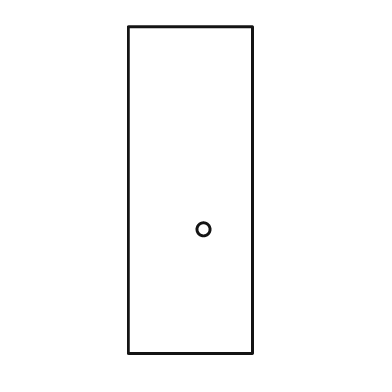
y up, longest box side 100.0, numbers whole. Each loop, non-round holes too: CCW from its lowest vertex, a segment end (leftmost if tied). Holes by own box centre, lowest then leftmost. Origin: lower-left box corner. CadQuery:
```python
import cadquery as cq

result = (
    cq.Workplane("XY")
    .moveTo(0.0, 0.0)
    .lineTo(38.0, 0.0)
    .lineTo(38.0, 100.0)
    .lineTo(0.0, 100.0)
    .close()
    .moveTo(23.0, 38.0)
    .circle(2.0)
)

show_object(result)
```